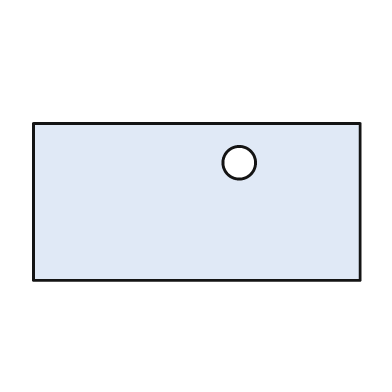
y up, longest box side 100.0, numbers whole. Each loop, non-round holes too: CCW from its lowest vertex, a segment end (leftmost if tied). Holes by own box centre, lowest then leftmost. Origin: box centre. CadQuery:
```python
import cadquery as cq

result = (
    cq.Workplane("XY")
    .moveTo(-50.0, -24.0)
    .lineTo(50.0, -24.0)
    .lineTo(50.0, 24.0)
    .lineTo(-50.0, 24.0)
    .close()
    .moveTo(13.0, 12.0)
    .circle(5.0)
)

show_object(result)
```